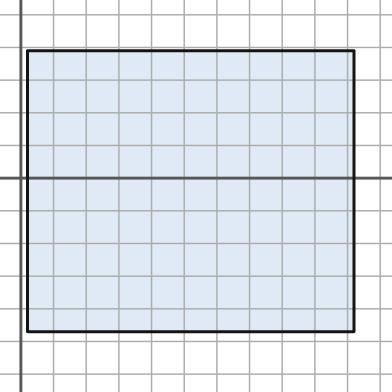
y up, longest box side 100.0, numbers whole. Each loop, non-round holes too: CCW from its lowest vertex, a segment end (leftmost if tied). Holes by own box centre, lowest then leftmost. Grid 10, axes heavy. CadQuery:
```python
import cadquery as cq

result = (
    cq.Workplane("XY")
    .moveTo(2.0, -47.0)
    .lineTo(102.0, -47.0)
    .lineTo(102.0, 39.0)
    .lineTo(2.0, 39.0)
    .close()
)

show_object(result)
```